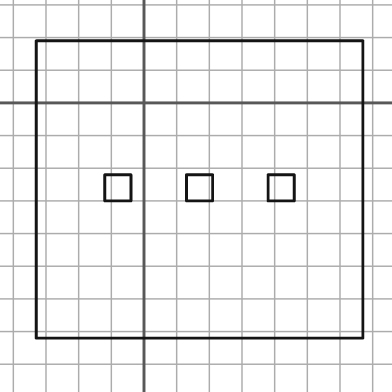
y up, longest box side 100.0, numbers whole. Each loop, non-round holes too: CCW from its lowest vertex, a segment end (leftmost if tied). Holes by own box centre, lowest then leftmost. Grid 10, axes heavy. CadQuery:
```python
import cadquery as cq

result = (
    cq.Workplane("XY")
    .moveTo(-33.0, -72.0)
    .lineTo(67.0, -72.0)
    .lineTo(67.0, 19.0)
    .lineTo(-33.0, 19.0)
    .close()
    .moveTo(-12.0, -30.0)
    .lineTo(-4.0, -30.0)
    .lineTo(-4.0, -22.0)
    .lineTo(-12.0, -22.0)
    .close()
    .moveTo(13.0, -30.0)
    .lineTo(21.0, -30.0)
    .lineTo(21.0, -22.0)
    .lineTo(13.0, -22.0)
    .close()
    .moveTo(38.0, -30.0)
    .lineTo(46.0, -30.0)
    .lineTo(46.0, -22.0)
    .lineTo(38.0, -22.0)
    .close()
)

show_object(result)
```